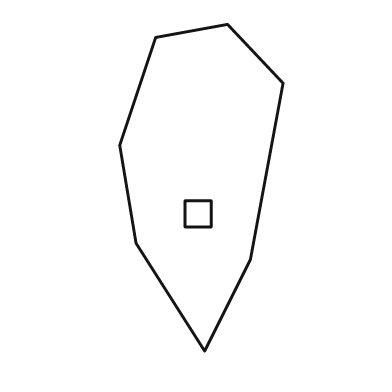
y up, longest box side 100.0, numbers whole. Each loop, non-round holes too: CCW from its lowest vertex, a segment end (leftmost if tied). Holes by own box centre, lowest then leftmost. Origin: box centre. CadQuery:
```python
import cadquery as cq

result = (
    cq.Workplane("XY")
    .moveTo(1.0, -50.0)
    .lineTo(15.0, -22.0)
    .lineTo(25.0, 32.0)
    .lineTo(8.0, 50.0)
    .lineTo(-14.0, 46.0)
    .lineTo(-25.0, 13.0)
    .lineTo(-20.0, -17.0)
    .close()
    .moveTo(-5.0, -12.0)
    .lineTo(3.0, -12.0)
    .lineTo(3.0, -4.0)
    .lineTo(-5.0, -4.0)
    .close()
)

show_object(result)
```